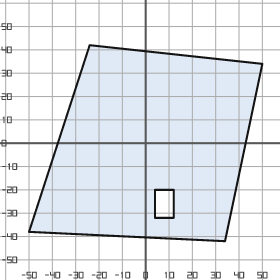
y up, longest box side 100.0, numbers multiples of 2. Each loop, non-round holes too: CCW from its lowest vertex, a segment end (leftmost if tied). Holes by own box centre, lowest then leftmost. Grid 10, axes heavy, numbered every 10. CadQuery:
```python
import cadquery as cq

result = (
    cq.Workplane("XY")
    .moveTo(34.0, -42.0)
    .lineTo(50.0, 34.0)
    .lineTo(-24.0, 42.0)
    .lineTo(-50.0, -38.0)
    .close()
    .moveTo(4.0, -32.0)
    .lineTo(12.0, -32.0)
    .lineTo(12.0, -20.0)
    .lineTo(4.0, -20.0)
    .close()
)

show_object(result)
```